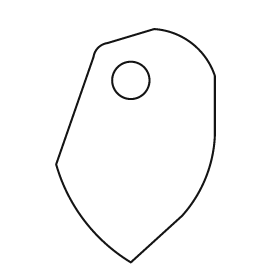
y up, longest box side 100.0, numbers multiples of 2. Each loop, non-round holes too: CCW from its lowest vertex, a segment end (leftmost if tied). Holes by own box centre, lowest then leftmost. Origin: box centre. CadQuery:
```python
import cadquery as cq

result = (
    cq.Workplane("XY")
    .moveTo(-2.0, -50.0)
    .lineTo(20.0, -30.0)
    .threePointArc((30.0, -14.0), (34.0, 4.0))
    .lineTo(34.0, 30.0)
    .threePointArc((24.0, 44.0), (8.0, 50.0))
    .lineTo(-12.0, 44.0)
    .threePointArc((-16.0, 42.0), (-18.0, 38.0))
    .lineTo(-34.0, -8.0)
    .threePointArc((-22.0, -32.0), (-2.0, -50.0))
    .close()
    .moveTo(-2.0, 28.0)
    .circle(8.0)
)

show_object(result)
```